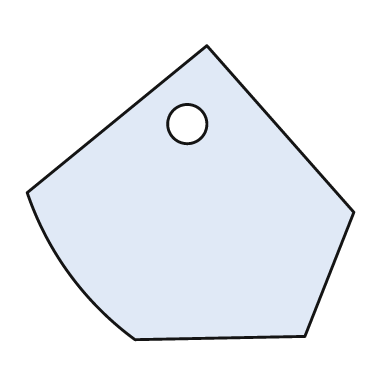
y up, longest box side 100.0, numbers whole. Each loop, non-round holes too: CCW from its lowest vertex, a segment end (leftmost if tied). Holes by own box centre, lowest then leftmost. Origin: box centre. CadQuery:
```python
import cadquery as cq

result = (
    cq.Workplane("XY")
    .moveTo(-17.0, -45.0)
    .lineTo(35.0, -44.0)
    .lineTo(50.0, -6.0)
    .lineTo(5.0, 45.0)
    .lineTo(-50.0, 0.0)
    .threePointArc((-37.0, -25.0), (-17.0, -45.0))
    .close()
    .moveTo(-1.0, 21.0)
    .circle(6.0)
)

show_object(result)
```